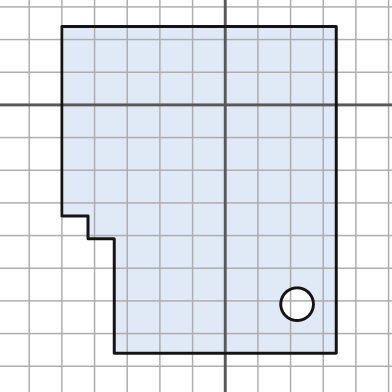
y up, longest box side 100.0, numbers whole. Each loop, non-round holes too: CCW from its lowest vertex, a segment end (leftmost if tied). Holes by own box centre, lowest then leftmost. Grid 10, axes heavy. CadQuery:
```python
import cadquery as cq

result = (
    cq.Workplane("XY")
    .moveTo(-34.0, -76.0)
    .lineTo(34.0, -76.0)
    .lineTo(34.0, 24.0)
    .lineTo(-50.0, 24.0)
    .lineTo(-50.0, -34.0)
    .lineTo(-42.0, -34.0)
    .lineTo(-42.0, -41.0)
    .lineTo(-34.0, -41.0)
    .close()
    .moveTo(22.0, -61.0)
    .circle(5.0)
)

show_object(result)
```